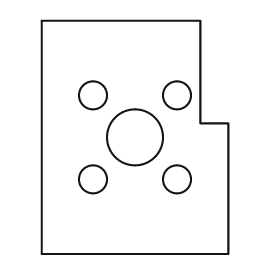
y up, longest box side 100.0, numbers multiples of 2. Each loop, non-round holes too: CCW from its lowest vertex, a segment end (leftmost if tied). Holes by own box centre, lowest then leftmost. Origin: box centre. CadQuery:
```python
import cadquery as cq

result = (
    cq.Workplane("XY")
    .moveTo(-40.0, -50.0)
    .lineTo(40.0, -50.0)
    .lineTo(40.0, 6.0)
    .lineTo(28.0, 6.0)
    .lineTo(28.0, 50.0)
    .lineTo(-40.0, 50.0)
    .close()
    .moveTo(-18.0, -18.0)
    .circle(6.0)
    .moveTo(18.0, -18.0)
    .circle(6.0)
    .moveTo(0.0, 0.0)
    .circle(12.0)
    .moveTo(-18.0, 18.0)
    .circle(6.0)
    .moveTo(18.0, 18.0)
    .circle(6.0)
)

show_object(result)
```